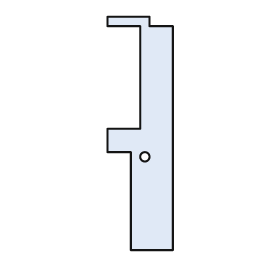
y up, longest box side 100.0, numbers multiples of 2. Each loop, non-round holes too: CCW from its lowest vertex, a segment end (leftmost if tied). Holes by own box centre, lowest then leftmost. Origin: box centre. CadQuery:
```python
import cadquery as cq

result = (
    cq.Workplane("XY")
    .moveTo(-4.0, -50.0)
    .lineTo(14.0, -50.0)
    .lineTo(14.0, 46.0)
    .lineTo(4.0, 46.0)
    .lineTo(4.0, 50.0)
    .lineTo(-14.0, 50.0)
    .lineTo(-14.0, 46.0)
    .lineTo(0.0, 46.0)
    .lineTo(0.0, 2.0)
    .lineTo(-14.0, 2.0)
    .lineTo(-14.0, -8.0)
    .lineTo(-4.0, -8.0)
    .close()
    .moveTo(2.0, -10.0)
    .circle(2.0)
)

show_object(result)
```